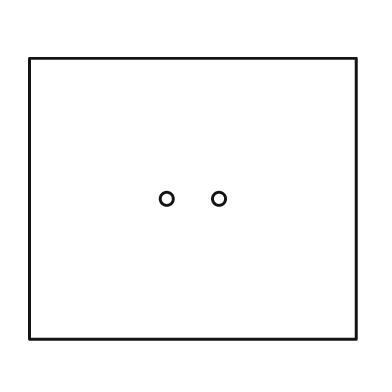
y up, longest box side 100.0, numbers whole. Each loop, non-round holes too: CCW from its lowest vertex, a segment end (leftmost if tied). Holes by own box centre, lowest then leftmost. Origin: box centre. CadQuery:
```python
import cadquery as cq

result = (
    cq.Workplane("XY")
    .moveTo(-50.0, -43.0)
    .lineTo(50.0, -43.0)
    .lineTo(50.0, 43.0)
    .lineTo(-50.0, 43.0)
    .close()
    .moveTo(-8.0, 0.0)
    .circle(2.0)
    .moveTo(8.0, 0.0)
    .circle(2.0)
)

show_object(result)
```